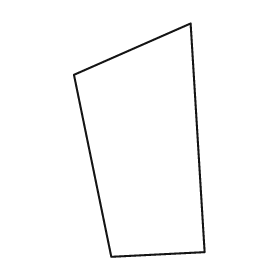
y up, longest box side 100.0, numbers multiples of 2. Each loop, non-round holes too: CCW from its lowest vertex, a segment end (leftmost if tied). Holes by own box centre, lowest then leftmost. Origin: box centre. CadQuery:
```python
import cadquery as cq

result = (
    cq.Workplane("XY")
    .moveTo(-12.0, -50.0)
    .lineTo(28.0, -48.0)
    .lineTo(22.0, 50.0)
    .lineTo(-28.0, 28.0)
    .close()
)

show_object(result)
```